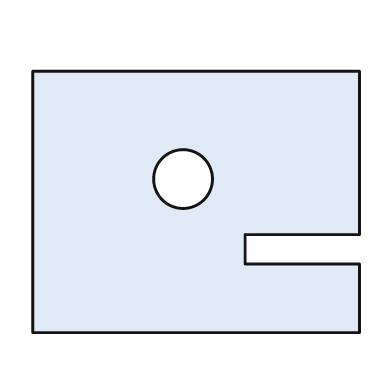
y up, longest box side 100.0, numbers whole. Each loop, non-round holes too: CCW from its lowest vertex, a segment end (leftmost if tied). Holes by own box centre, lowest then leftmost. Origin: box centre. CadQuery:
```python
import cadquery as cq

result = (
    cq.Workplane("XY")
    .moveTo(-50.0, -40.0)
    .lineTo(50.0, -40.0)
    .lineTo(50.0, -19.0)
    .lineTo(15.0, -19.0)
    .lineTo(15.0, -10.0)
    .lineTo(50.0, -10.0)
    .lineTo(50.0, 40.0)
    .lineTo(-50.0, 40.0)
    .close()
    .moveTo(-4.0, 7.0)
    .circle(9.0)
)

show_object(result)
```